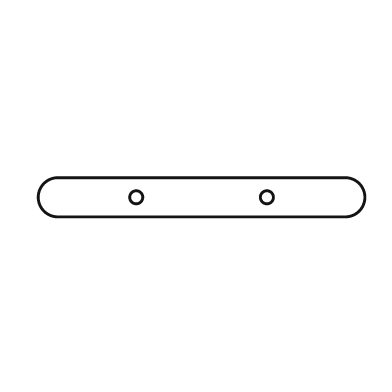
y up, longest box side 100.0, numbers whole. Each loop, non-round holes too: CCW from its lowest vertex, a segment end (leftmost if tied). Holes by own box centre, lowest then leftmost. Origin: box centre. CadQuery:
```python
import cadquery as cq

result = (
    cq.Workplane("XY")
    .moveTo(-44.0, -6.0)
    .lineTo(44.0, -6.0)
    .threePointArc((50.0, 0.0), (44.0, 6.0))
    .lineTo(-44.0, 6.0)
    .threePointArc((-50.0, 0.0), (-44.0, -6.0))
    .close()
    .moveTo(-20.0, 0.0)
    .circle(2.0)
    .moveTo(20.0, 0.0)
    .circle(2.0)
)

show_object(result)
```